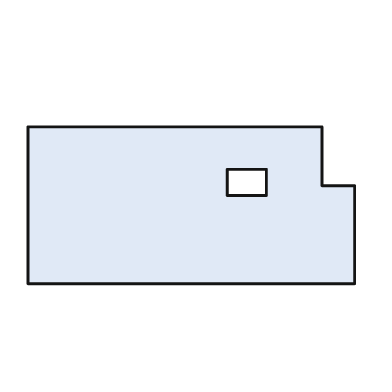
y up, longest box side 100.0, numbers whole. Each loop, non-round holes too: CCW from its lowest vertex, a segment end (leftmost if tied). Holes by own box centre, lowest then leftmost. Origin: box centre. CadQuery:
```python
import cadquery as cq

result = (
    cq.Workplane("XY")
    .moveTo(-50.0, -24.0)
    .lineTo(50.0, -24.0)
    .lineTo(50.0, 6.0)
    .lineTo(40.0, 6.0)
    .lineTo(40.0, 24.0)
    .lineTo(-50.0, 24.0)
    .close()
    .moveTo(11.0, 3.0)
    .lineTo(23.0, 3.0)
    .lineTo(23.0, 11.0)
    .lineTo(11.0, 11.0)
    .close()
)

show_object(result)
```